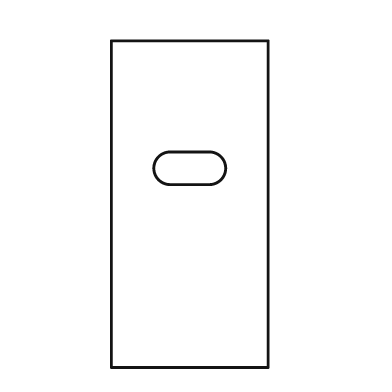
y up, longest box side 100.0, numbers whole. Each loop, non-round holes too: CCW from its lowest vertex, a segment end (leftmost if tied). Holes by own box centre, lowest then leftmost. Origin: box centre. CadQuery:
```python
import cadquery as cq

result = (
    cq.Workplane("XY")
    .moveTo(-24.0, -50.0)
    .lineTo(24.0, -50.0)
    .lineTo(24.0, 50.0)
    .lineTo(-24.0, 50.0)
    .close()
    .moveTo(-6.0, 6.0)
    .lineTo(6.0, 6.0)
    .threePointArc((11.0, 11.0), (6.0, 16.0))
    .lineTo(-6.0, 16.0)
    .threePointArc((-11.0, 11.0), (-6.0, 6.0))
    .close()
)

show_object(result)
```